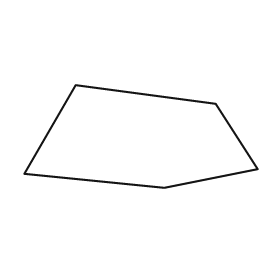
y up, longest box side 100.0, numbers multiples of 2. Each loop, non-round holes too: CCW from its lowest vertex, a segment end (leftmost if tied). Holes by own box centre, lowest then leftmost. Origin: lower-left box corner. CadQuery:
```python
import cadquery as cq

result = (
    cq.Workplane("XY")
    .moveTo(60.0, 0.0)
    .lineTo(100.0, 8.0)
    .lineTo(82.0, 36.0)
    .lineTo(22.0, 44.0)
    .lineTo(0.0, 6.0)
    .close()
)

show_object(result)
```